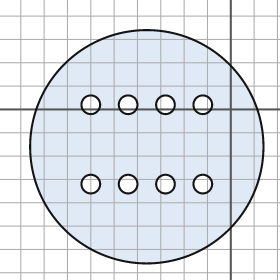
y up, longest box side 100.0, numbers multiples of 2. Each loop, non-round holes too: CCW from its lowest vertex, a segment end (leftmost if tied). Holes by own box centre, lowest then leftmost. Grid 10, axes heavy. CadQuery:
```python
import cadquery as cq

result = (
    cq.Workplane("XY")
    .moveTo(-36.0, -16.0)
    .circle(50.0)
    .moveTo(-60.0, -32.0)
    .circle(4.0)
    .moveTo(-44.0, -32.0)
    .circle(4.0)
    .moveTo(-28.0, -32.0)
    .circle(4.0)
    .moveTo(-12.0, -32.0)
    .circle(4.0)
    .moveTo(-60.0, 2.0)
    .circle(4.0)
    .moveTo(-44.0, 2.0)
    .circle(4.0)
    .moveTo(-28.0, 2.0)
    .circle(4.0)
    .moveTo(-12.0, 2.0)
    .circle(4.0)
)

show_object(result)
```